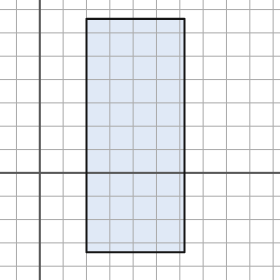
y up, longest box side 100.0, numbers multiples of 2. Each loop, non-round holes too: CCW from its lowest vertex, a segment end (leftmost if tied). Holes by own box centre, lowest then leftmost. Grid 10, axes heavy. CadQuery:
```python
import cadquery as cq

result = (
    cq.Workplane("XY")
    .moveTo(20.0, -34.0)
    .lineTo(62.0, -34.0)
    .lineTo(62.0, 66.0)
    .lineTo(20.0, 66.0)
    .close()
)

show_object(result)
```